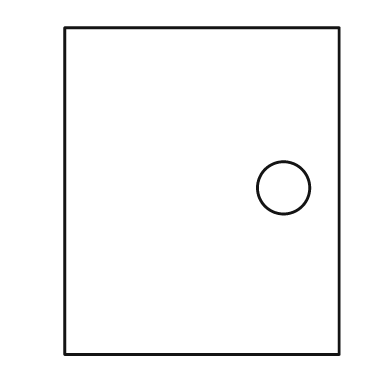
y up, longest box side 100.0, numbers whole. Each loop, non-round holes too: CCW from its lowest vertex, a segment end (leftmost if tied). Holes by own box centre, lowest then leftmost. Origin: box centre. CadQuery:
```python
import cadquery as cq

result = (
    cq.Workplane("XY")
    .moveTo(-42.0, -50.0)
    .lineTo(42.0, -50.0)
    .lineTo(42.0, 50.0)
    .lineTo(-42.0, 50.0)
    .close()
    .moveTo(25.0, 1.0)
    .circle(8.0)
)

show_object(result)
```